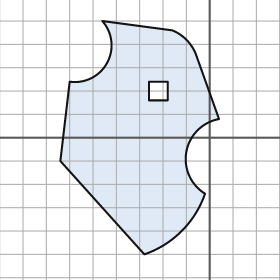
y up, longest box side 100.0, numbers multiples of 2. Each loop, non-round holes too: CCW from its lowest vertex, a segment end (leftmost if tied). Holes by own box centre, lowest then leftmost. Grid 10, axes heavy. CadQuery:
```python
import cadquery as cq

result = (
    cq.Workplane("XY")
    .moveTo(-28.0, -50.0)
    .threePointArc((-12.0, -40.0), (-2.0, -24.0))
    .threePointArc((-10.0, -6.0), (4.0, 8.0))
    .lineTo(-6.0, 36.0)
    .threePointArc((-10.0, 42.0), (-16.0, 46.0))
    .lineTo(-46.0, 50.0)
    .threePointArc((-44.0, 32.0), (-60.0, 24.0))
    .lineTo(-64.0, -10.0)
    .close()
    .moveTo(-26.0, 16.0)
    .lineTo(-18.0, 16.0)
    .lineTo(-18.0, 24.0)
    .lineTo(-26.0, 24.0)
    .close()
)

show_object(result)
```